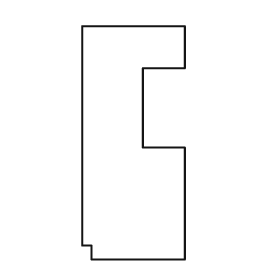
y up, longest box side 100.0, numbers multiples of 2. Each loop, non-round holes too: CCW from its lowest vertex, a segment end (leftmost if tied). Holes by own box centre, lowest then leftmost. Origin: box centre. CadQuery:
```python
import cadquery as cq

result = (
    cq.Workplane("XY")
    .moveTo(-18.0, -50.0)
    .lineTo(22.0, -50.0)
    .lineTo(22.0, -2.0)
    .lineTo(4.0, -2.0)
    .lineTo(4.0, 32.0)
    .lineTo(22.0, 32.0)
    .lineTo(22.0, 50.0)
    .lineTo(-22.0, 50.0)
    .lineTo(-22.0, -44.0)
    .lineTo(-18.0, -44.0)
    .close()
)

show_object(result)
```